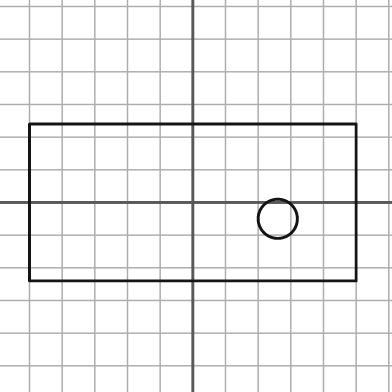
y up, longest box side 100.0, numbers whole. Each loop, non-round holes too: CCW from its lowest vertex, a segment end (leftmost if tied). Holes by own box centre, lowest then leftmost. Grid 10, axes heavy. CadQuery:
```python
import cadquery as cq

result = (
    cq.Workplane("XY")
    .moveTo(-50.0, -24.0)
    .lineTo(50.0, -24.0)
    .lineTo(50.0, 24.0)
    .lineTo(-50.0, 24.0)
    .close()
    .moveTo(26.0, -5.0)
    .circle(6.0)
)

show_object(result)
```